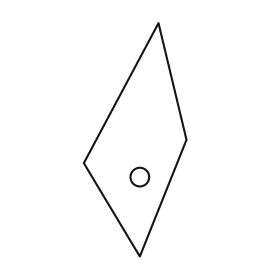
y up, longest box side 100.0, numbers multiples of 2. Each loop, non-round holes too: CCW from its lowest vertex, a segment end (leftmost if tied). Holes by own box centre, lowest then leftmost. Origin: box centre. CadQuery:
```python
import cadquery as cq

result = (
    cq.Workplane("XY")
    .moveTo(2.0, -50.0)
    .lineTo(22.0, 0.0)
    .lineTo(10.0, 50.0)
    .lineTo(-22.0, -10.0)
    .close()
    .moveTo(2.0, -16.0)
    .circle(4.0)
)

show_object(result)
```